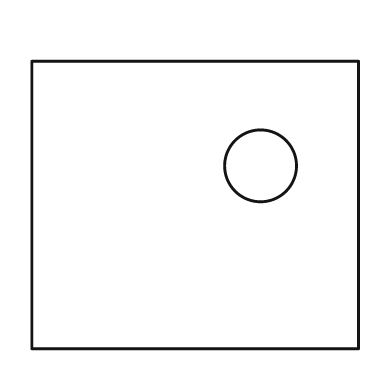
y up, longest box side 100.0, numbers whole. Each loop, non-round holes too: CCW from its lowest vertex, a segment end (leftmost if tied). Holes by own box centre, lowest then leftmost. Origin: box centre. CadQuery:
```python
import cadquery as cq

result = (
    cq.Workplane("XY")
    .moveTo(-50.0, -44.0)
    .lineTo(50.0, -44.0)
    .lineTo(50.0, 44.0)
    .lineTo(-50.0, 44.0)
    .close()
    .moveTo(20.0, 12.0)
    .circle(11.0)
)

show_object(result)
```